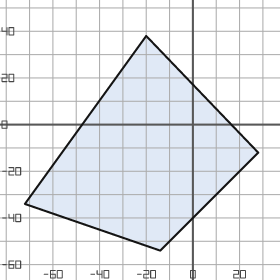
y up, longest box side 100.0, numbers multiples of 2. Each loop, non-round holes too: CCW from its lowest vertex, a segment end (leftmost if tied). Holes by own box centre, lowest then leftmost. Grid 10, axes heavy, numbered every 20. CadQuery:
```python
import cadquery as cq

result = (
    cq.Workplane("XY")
    .moveTo(-14.0, -54.0)
    .lineTo(28.0, -12.0)
    .lineTo(-20.0, 38.0)
    .lineTo(-72.0, -34.0)
    .close()
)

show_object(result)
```